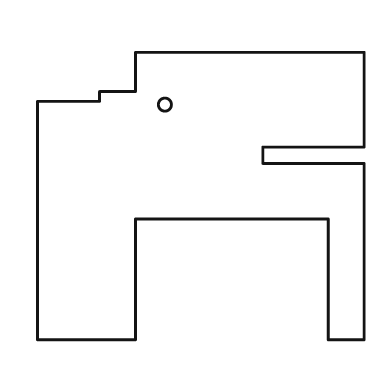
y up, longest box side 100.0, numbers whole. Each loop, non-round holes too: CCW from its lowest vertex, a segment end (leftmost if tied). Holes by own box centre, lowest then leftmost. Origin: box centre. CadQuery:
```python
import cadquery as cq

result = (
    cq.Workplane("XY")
    .moveTo(-50.0, -44.0)
    .lineTo(-20.0, -44.0)
    .lineTo(-20.0, -7.0)
    .lineTo(39.0, -7.0)
    .lineTo(39.0, -44.0)
    .lineTo(50.0, -44.0)
    .lineTo(50.0, 10.0)
    .lineTo(19.0, 10.0)
    .lineTo(19.0, 15.0)
    .lineTo(50.0, 15.0)
    .lineTo(50.0, 44.0)
    .lineTo(-20.0, 44.0)
    .lineTo(-20.0, 32.0)
    .lineTo(-31.0, 32.0)
    .lineTo(-31.0, 29.0)
    .lineTo(-50.0, 29.0)
    .close()
    .moveTo(-11.0, 28.0)
    .circle(2.0)
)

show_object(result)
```